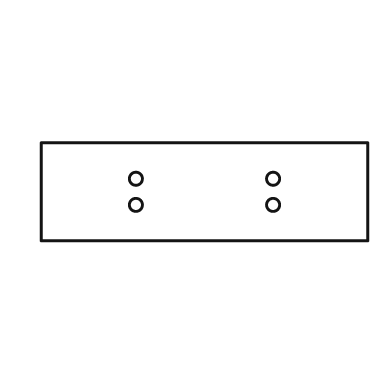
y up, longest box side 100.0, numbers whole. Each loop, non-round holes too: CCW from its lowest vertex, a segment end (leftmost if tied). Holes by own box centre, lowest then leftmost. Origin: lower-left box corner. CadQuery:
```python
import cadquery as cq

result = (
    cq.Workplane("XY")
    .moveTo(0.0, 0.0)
    .lineTo(100.0, 0.0)
    .lineTo(100.0, 30.0)
    .lineTo(0.0, 30.0)
    .close()
    .moveTo(29.0, 11.0)
    .circle(2.0)
    .moveTo(71.0, 11.0)
    .circle(2.0)
    .moveTo(29.0, 19.0)
    .circle(2.0)
    .moveTo(71.0, 19.0)
    .circle(2.0)
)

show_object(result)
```